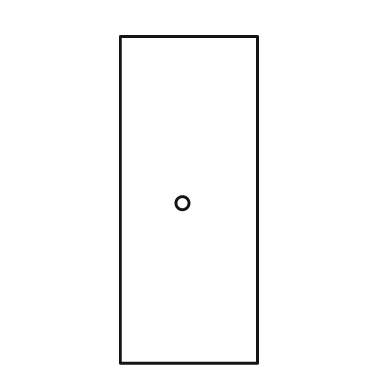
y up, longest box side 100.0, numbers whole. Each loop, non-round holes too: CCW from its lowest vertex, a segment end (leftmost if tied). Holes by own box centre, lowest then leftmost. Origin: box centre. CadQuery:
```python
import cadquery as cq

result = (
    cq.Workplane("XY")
    .moveTo(-21.0, -50.0)
    .lineTo(21.0, -50.0)
    .lineTo(21.0, 50.0)
    .lineTo(-21.0, 50.0)
    .close()
    .moveTo(-2.0, -1.0)
    .circle(2.0)
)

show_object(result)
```